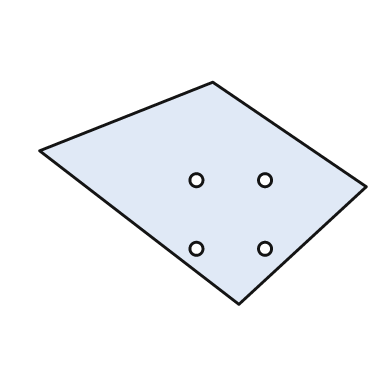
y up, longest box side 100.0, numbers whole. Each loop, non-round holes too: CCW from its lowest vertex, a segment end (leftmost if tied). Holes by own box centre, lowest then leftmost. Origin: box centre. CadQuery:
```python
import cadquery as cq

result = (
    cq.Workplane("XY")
    .moveTo(11.0, -34.0)
    .lineTo(50.0, 2.0)
    .lineTo(3.0, 34.0)
    .lineTo(-50.0, 13.0)
    .close()
    .moveTo(-2.0, -17.0)
    .circle(2.0)
    .moveTo(19.0, -17.0)
    .circle(2.0)
    .moveTo(-2.0, 4.0)
    .circle(2.0)
    .moveTo(19.0, 4.0)
    .circle(2.0)
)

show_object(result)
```